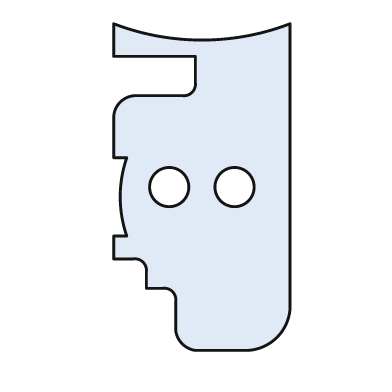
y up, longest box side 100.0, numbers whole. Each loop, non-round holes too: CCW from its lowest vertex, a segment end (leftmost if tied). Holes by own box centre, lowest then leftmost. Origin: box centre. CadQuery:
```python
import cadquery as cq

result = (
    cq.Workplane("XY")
    .moveTo(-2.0, -50.0)
    .lineTo(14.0, -50.0)
    .threePointArc((23.0, -46.0), (27.0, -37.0))
    .lineTo(27.0, 50.0)
    .threePointArc((0.0, 45.0), (-27.0, 50.0))
    .lineTo(-27.0, 40.0)
    .lineTo(-2.0, 40.0)
    .lineTo(-2.0, 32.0)
    .threePointArc((-3.0, 29.0), (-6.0, 28.0))
    .lineTo(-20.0, 28.0)
    .threePointArc((-25.0, 26.0), (-27.0, 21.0))
    .lineTo(-27.0, 9.0)
    .lineTo(-23.0, 9.0)
    .threePointArc((-25.0, -3.0), (-23.0, -15.0))
    .lineTo(-27.0, -15.0)
    .lineTo(-27.0, -22.0)
    .lineTo(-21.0, -22.0)
    .threePointArc((-18.0, -23.0), (-17.0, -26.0))
    .lineTo(-17.0, -31.0)
    .lineTo(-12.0, -31.0)
    .threePointArc((-9.0, -32.0), (-8.0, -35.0))
    .lineTo(-8.0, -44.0)
    .threePointArc((-6.0, -48.0), (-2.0, -50.0))
    .close()
    .moveTo(-10.0, 0.0)
    .circle(6.0)
    .moveTo(10.0, 0.0)
    .circle(6.0)
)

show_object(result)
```